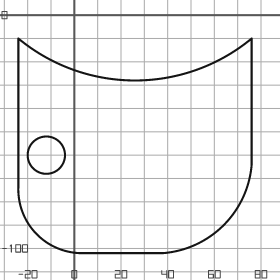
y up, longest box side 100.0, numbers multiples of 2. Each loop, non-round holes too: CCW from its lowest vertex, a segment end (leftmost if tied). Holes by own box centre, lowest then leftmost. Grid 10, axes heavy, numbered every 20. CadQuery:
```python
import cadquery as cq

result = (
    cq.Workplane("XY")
    .moveTo(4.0, -102.0)
    .lineTo(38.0, -102.0)
    .threePointArc((64.0, -90.0), (76.0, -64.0))
    .lineTo(76.0, -10.0)
    .threePointArc((26.0, -28.0), (-24.0, -10.0))
    .lineTo(-24.0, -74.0)
    .threePointArc((-16.0, -94.0), (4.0, -102.0))
    .close()
    .moveTo(-12.0, -60.0)
    .circle(8.0)
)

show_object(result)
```